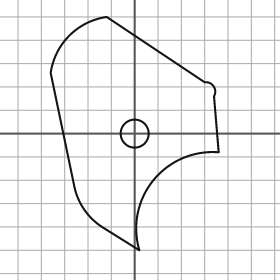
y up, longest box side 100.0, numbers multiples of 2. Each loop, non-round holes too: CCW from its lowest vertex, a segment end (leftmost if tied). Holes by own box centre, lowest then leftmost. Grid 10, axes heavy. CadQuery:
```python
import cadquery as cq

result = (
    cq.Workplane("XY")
    .moveTo(2.0, -50.0)
    .threePointArc((8.0, -20.0), (36.0, -8.0))
    .lineTo(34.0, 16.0)
    .threePointArc((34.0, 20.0), (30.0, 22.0))
    .lineTo(-12.0, 50.0)
    .threePointArc((-28.0, 42.0), (-36.0, 26.0))
    .lineTo(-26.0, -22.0)
    .threePointArc((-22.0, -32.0), (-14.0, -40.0))
    .close()
    .moveTo(0.0, 0.0)
    .circle(6.0)
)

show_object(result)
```